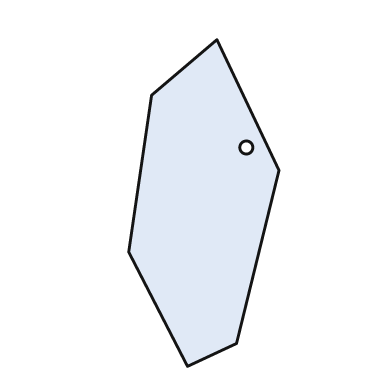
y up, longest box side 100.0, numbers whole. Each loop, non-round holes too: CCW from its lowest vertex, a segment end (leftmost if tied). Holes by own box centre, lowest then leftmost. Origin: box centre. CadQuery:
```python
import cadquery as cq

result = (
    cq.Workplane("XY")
    .moveTo(-5.0, -50.0)
    .lineTo(10.0, -43.0)
    .lineTo(23.0, 10.0)
    .lineTo(4.0, 50.0)
    .lineTo(-16.0, 33.0)
    .lineTo(-23.0, -15.0)
    .close()
    .moveTo(13.0, 17.0)
    .circle(2.0)
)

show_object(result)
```